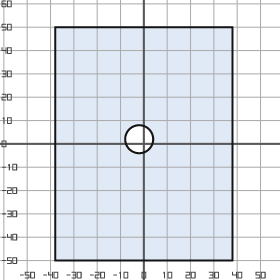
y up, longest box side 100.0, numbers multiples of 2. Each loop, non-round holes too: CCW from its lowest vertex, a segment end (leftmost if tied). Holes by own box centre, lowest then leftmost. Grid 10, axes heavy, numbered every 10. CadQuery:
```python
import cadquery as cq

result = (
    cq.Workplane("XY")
    .moveTo(-38.0, -50.0)
    .lineTo(38.0, -50.0)
    .lineTo(38.0, 50.0)
    .lineTo(-38.0, 50.0)
    .close()
    .moveTo(-2.0, 2.0)
    .circle(6.0)
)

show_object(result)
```